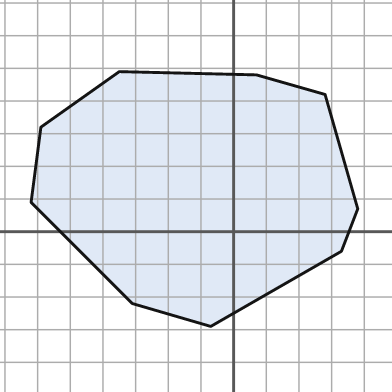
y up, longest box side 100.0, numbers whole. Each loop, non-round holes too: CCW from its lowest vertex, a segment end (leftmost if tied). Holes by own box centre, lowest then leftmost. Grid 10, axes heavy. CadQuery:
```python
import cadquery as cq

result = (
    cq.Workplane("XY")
    .moveTo(-7.0, -29.0)
    .lineTo(33.0, -6.0)
    .lineTo(38.0, 7.0)
    .lineTo(28.0, 42.0)
    .lineTo(7.0, 48.0)
    .lineTo(-35.0, 49.0)
    .lineTo(-59.0, 32.0)
    .lineTo(-62.0, 9.0)
    .lineTo(-31.0, -22.0)
    .close()
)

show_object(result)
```